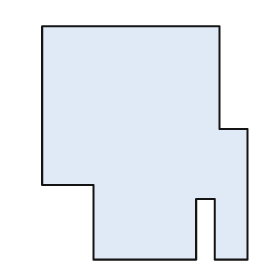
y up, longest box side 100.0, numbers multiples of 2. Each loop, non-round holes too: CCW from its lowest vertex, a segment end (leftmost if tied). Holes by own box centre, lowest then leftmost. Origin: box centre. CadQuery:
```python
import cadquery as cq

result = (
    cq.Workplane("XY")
    .moveTo(-22.0, -50.0)
    .lineTo(22.0, -50.0)
    .lineTo(22.0, -24.0)
    .lineTo(30.0, -24.0)
    .lineTo(30.0, -50.0)
    .lineTo(44.0, -50.0)
    .lineTo(44.0, 6.0)
    .lineTo(32.0, 6.0)
    .lineTo(32.0, 50.0)
    .lineTo(-44.0, 50.0)
    .lineTo(-44.0, -18.0)
    .lineTo(-22.0, -18.0)
    .close()
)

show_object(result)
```